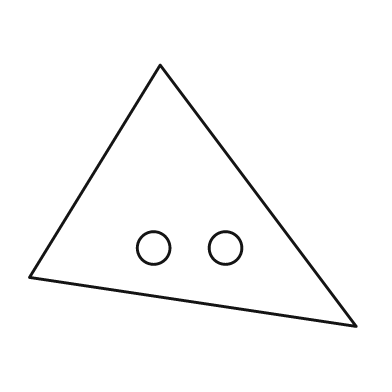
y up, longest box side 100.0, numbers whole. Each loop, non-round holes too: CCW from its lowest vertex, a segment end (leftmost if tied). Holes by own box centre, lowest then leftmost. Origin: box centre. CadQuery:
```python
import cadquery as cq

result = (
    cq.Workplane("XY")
    .moveTo(50.0, -40.0)
    .lineTo(-10.0, 40.0)
    .lineTo(-50.0, -25.0)
    .close()
    .moveTo(-12.0, -16.0)
    .circle(5.0)
    .moveTo(10.0, -16.0)
    .circle(5.0)
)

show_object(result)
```